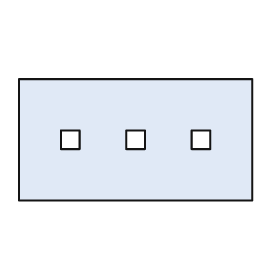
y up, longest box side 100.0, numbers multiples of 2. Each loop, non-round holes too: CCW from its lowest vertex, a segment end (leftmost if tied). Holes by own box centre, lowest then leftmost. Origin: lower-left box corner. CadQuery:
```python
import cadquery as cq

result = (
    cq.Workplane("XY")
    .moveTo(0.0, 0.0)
    .lineTo(100.0, 0.0)
    .lineTo(100.0, 52.0)
    .lineTo(0.0, 52.0)
    .close()
    .moveTo(18.0, 22.0)
    .lineTo(26.0, 22.0)
    .lineTo(26.0, 30.0)
    .lineTo(18.0, 30.0)
    .close()
    .moveTo(46.0, 22.0)
    .lineTo(54.0, 22.0)
    .lineTo(54.0, 30.0)
    .lineTo(46.0, 30.0)
    .close()
    .moveTo(74.0, 22.0)
    .lineTo(82.0, 22.0)
    .lineTo(82.0, 30.0)
    .lineTo(74.0, 30.0)
    .close()
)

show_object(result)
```